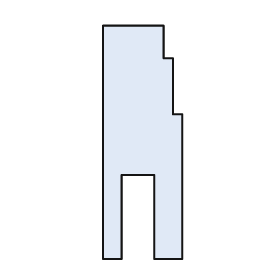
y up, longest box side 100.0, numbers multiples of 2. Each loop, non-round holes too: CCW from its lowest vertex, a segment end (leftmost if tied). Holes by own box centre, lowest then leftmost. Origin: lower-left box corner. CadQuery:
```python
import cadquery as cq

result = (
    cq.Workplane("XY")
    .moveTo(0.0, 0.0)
    .lineTo(8.0, 0.0)
    .lineTo(8.0, 36.0)
    .lineTo(22.0, 36.0)
    .lineTo(22.0, 0.0)
    .lineTo(34.0, 0.0)
    .lineTo(34.0, 62.0)
    .lineTo(30.0, 62.0)
    .lineTo(30.0, 86.0)
    .lineTo(26.0, 86.0)
    .lineTo(26.0, 100.0)
    .lineTo(0.0, 100.0)
    .close()
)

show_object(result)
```